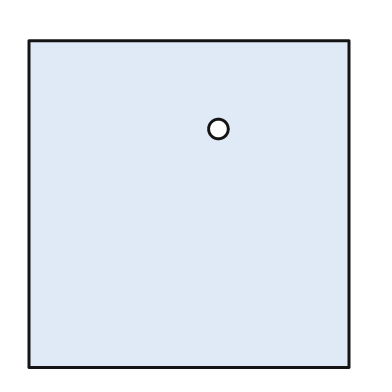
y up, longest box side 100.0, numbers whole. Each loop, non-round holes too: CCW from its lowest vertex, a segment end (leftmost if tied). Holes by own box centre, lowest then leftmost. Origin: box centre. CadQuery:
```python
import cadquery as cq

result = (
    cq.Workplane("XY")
    .moveTo(-49.0, -50.0)
    .lineTo(49.0, -50.0)
    .lineTo(49.0, 50.0)
    .lineTo(-49.0, 50.0)
    .close()
    .moveTo(9.0, 23.0)
    .circle(3.0)
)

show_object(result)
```